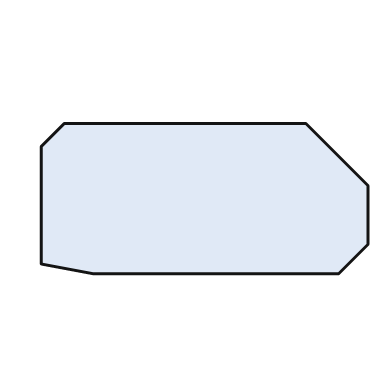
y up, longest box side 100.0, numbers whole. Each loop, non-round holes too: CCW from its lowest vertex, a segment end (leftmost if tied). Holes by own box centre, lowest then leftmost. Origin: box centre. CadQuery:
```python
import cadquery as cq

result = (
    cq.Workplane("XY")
    .moveTo(-34.0, -23.0)
    .lineTo(41.0, -23.0)
    .lineTo(50.0, -14.0)
    .lineTo(50.0, 4.0)
    .lineTo(31.0, 23.0)
    .lineTo(-43.0, 23.0)
    .lineTo(-50.0, 16.0)
    .lineTo(-50.0, -20.0)
    .close()
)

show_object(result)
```